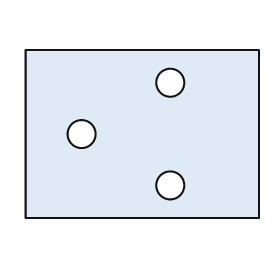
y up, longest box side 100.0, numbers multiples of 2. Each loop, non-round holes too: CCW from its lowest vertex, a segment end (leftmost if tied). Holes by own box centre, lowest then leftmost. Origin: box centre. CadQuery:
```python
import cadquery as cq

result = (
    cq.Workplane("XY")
    .moveTo(-50.0, -36.0)
    .lineTo(50.0, -36.0)
    .lineTo(50.0, 36.0)
    .lineTo(-50.0, 36.0)
    .close()
    .moveTo(12.0, -22.0)
    .circle(6.0)
    .moveTo(-26.0, 0.0)
    .circle(6.0)
    .moveTo(12.0, 22.0)
    .circle(6.0)
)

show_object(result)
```